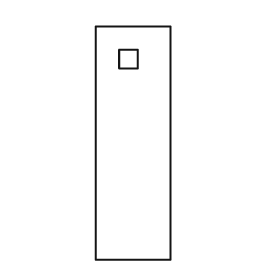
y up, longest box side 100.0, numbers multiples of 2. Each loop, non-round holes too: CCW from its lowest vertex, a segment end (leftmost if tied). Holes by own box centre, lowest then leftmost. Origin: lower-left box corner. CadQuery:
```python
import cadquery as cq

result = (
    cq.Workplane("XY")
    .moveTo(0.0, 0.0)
    .lineTo(32.0, 0.0)
    .lineTo(32.0, 100.0)
    .lineTo(0.0, 100.0)
    .close()
    .moveTo(10.0, 82.0)
    .lineTo(18.0, 82.0)
    .lineTo(18.0, 90.0)
    .lineTo(10.0, 90.0)
    .close()
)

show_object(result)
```